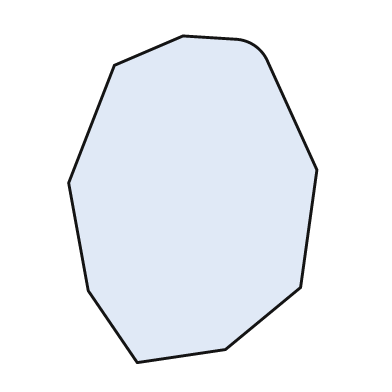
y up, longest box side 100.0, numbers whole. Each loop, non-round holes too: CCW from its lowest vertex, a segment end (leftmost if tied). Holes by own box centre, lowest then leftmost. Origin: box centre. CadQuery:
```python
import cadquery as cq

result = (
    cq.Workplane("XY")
    .moveTo(-17.0, -50.0)
    .lineTo(10.0, -46.0)
    .lineTo(33.0, -27.0)
    .lineTo(38.0, 9.0)
    .lineTo(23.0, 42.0)
    .threePointArc((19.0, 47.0), (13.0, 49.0))
    .lineTo(-3.0, 50.0)
    .lineTo(-24.0, 41.0)
    .lineTo(-38.0, 5.0)
    .lineTo(-32.0, -28.0)
    .close()
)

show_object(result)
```